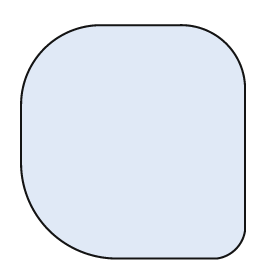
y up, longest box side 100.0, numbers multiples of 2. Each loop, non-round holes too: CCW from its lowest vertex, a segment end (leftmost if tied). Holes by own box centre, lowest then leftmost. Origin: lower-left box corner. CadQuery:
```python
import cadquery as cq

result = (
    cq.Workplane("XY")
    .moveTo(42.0, 0.0)
    .lineTo(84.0, 0.0)
    .threePointArc((92.0, 4.0), (96.0, 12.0))
    .lineTo(96.0, 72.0)
    .threePointArc((88.0, 92.0), (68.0, 100.0))
    .lineTo(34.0, 100.0)
    .threePointArc((10.0, 90.0), (0.0, 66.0))
    .lineTo(0.0, 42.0)
    .threePointArc((12.0, 12.0), (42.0, 0.0))
    .close()
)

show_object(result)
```